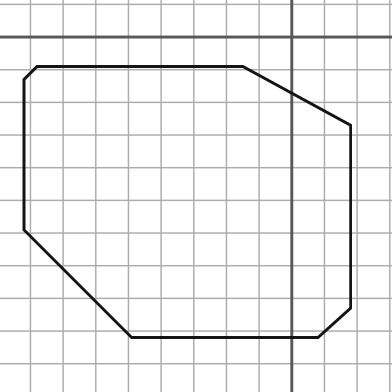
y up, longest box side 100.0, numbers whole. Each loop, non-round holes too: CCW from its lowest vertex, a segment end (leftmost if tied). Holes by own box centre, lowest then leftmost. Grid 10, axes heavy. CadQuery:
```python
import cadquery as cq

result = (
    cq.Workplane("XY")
    .moveTo(-49.0, -92.0)
    .lineTo(8.0, -92.0)
    .lineTo(18.0, -83.0)
    .lineTo(18.0, -27.0)
    .lineTo(-15.0, -9.0)
    .lineTo(-78.0, -9.0)
    .lineTo(-82.0, -13.0)
    .lineTo(-82.0, -59.0)
    .close()
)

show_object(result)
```